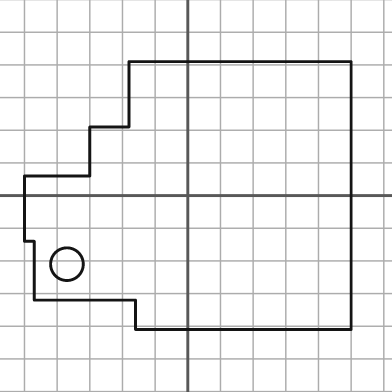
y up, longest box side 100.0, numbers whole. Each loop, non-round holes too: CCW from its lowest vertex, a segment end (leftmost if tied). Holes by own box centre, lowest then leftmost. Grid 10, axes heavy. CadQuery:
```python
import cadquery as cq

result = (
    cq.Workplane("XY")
    .moveTo(-16.0, -41.0)
    .lineTo(50.0, -41.0)
    .lineTo(50.0, 41.0)
    .lineTo(-18.0, 41.0)
    .lineTo(-18.0, 21.0)
    .lineTo(-30.0, 21.0)
    .lineTo(-30.0, 6.0)
    .lineTo(-50.0, 6.0)
    .lineTo(-50.0, -14.0)
    .lineTo(-47.0, -14.0)
    .lineTo(-47.0, -32.0)
    .lineTo(-16.0, -32.0)
    .close()
    .moveTo(-37.0, -21.0)
    .circle(5.0)
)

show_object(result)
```